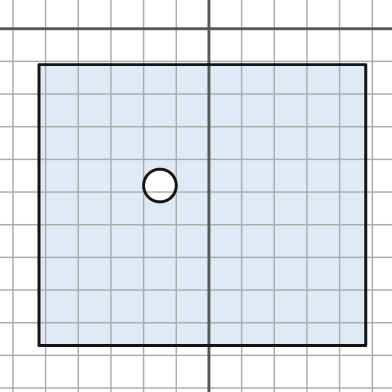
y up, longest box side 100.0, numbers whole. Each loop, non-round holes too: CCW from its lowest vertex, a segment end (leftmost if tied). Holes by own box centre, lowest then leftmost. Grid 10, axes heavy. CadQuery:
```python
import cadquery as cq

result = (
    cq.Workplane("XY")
    .moveTo(-52.0, -97.0)
    .lineTo(48.0, -97.0)
    .lineTo(48.0, -11.0)
    .lineTo(-52.0, -11.0)
    .close()
    .moveTo(-15.0, -48.0)
    .circle(5.0)
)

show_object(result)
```